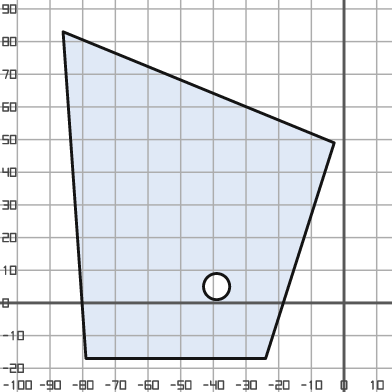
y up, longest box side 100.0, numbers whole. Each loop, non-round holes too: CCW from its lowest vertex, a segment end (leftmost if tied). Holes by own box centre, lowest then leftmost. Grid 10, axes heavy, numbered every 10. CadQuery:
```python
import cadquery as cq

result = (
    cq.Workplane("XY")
    .moveTo(-79.0, -17.0)
    .lineTo(-24.0, -17.0)
    .lineTo(-3.0, 49.0)
    .lineTo(-86.0, 83.0)
    .close()
    .moveTo(-39.0, 5.0)
    .circle(4.0)
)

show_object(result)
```